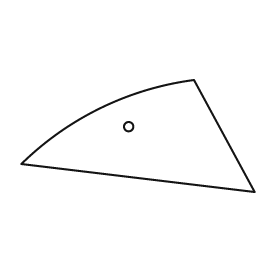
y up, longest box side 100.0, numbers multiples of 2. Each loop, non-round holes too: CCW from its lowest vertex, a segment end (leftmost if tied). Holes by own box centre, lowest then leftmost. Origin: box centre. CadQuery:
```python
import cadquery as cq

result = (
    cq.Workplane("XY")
    .moveTo(50.0, -24.0)
    .lineTo(24.0, 24.0)
    .threePointArc((-16.0, 12.0), (-50.0, -12.0))
    .close()
    .moveTo(-4.0, 4.0)
    .circle(2.0)
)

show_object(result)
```